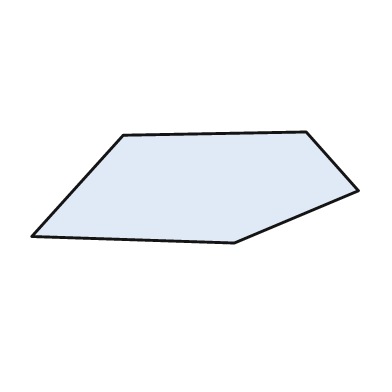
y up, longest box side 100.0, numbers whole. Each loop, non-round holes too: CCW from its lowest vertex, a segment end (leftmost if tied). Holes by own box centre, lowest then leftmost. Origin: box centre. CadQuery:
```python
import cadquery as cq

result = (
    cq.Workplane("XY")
    .moveTo(12.0, -17.0)
    .lineTo(50.0, -1.0)
    .lineTo(34.0, 17.0)
    .lineTo(-22.0, 16.0)
    .lineTo(-50.0, -15.0)
    .close()
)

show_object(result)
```